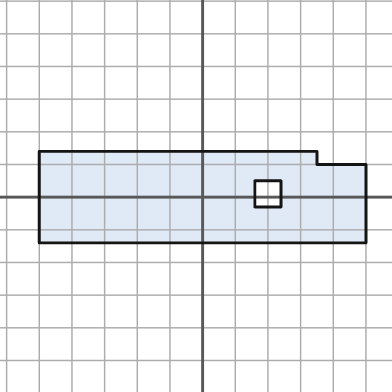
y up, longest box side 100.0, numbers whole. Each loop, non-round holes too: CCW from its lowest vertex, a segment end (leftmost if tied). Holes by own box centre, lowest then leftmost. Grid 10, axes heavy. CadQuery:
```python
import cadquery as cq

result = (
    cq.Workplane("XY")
    .moveTo(-50.0, -14.0)
    .lineTo(50.0, -14.0)
    .lineTo(50.0, 10.0)
    .lineTo(35.0, 10.0)
    .lineTo(35.0, 14.0)
    .lineTo(-50.0, 14.0)
    .close()
    .moveTo(16.0, -3.0)
    .lineTo(24.0, -3.0)
    .lineTo(24.0, 5.0)
    .lineTo(16.0, 5.0)
    .close()
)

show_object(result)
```